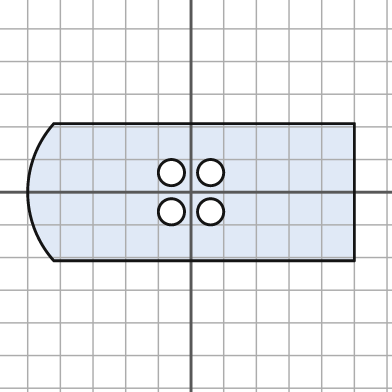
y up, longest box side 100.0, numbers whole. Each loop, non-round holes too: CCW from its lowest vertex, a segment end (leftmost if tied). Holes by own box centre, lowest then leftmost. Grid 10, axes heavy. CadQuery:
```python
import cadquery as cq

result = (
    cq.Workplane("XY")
    .moveTo(-42.0, -21.0)
    .lineTo(50.0, -21.0)
    .lineTo(50.0, 21.0)
    .lineTo(-42.0, 21.0)
    .threePointArc((-50.0, 0.0), (-42.0, -21.0))
    .close()
    .moveTo(-6.0, -6.0)
    .circle(4.0)
    .moveTo(6.0, -6.0)
    .circle(4.0)
    .moveTo(-6.0, 6.0)
    .circle(4.0)
    .moveTo(6.0, 6.0)
    .circle(4.0)
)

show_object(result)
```